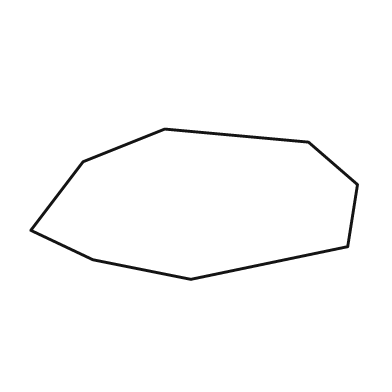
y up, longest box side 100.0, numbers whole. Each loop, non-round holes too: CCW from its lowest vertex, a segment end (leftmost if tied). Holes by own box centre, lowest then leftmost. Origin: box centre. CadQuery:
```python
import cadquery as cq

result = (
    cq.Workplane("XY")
    .moveTo(-1.0, -23.0)
    .lineTo(47.0, -13.0)
    .lineTo(50.0, 6.0)
    .lineTo(35.0, 19.0)
    .lineTo(-9.0, 23.0)
    .lineTo(-34.0, 13.0)
    .lineTo(-50.0, -8.0)
    .lineTo(-31.0, -17.0)
    .close()
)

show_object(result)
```